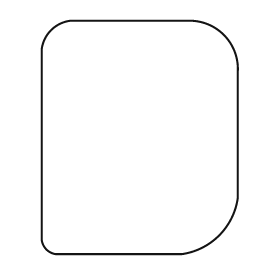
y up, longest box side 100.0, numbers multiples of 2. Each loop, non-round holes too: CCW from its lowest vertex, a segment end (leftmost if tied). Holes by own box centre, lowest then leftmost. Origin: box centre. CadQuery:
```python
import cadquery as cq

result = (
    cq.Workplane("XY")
    .moveTo(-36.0, -50.0)
    .lineTo(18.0, -50.0)
    .threePointArc((34.0, -42.0), (42.0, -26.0))
    .lineTo(42.0, 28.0)
    .threePointArc((36.0, 44.0), (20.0, 50.0))
    .lineTo(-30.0, 50.0)
    .threePointArc((-38.0, 46.0), (-42.0, 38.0))
    .lineTo(-42.0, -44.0)
    .threePointArc((-40.0, -48.0), (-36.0, -50.0))
    .close()
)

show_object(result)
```